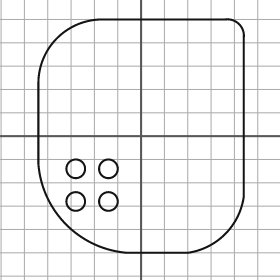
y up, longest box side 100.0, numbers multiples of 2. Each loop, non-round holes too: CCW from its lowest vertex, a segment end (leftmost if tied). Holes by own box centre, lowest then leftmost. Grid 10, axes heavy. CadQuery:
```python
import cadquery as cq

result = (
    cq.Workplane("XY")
    .moveTo(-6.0, -50.0)
    .lineTo(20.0, -50.0)
    .threePointArc((36.0, -42.0), (44.0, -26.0))
    .lineTo(44.0, 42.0)
    .threePointArc((42.0, 48.0), (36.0, 50.0))
    .lineTo(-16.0, 50.0)
    .threePointArc((-36.0, 42.0), (-44.0, 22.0))
    .lineTo(-44.0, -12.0)
    .threePointArc((-32.0, -38.0), (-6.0, -50.0))
    .close()
    .moveTo(-28.0, -28.0)
    .circle(4.0)
    .moveTo(-14.0, -28.0)
    .circle(4.0)
    .moveTo(-28.0, -14.0)
    .circle(4.0)
    .moveTo(-14.0, -14.0)
    .circle(4.0)
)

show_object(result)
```